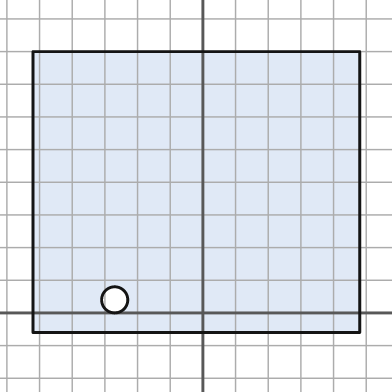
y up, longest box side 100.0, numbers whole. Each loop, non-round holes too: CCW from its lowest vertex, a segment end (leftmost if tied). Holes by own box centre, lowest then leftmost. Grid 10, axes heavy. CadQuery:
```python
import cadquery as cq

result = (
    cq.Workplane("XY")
    .moveTo(-52.0, -6.0)
    .lineTo(48.0, -6.0)
    .lineTo(48.0, 80.0)
    .lineTo(-52.0, 80.0)
    .close()
    .moveTo(-27.0, 4.0)
    .circle(4.0)
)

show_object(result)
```